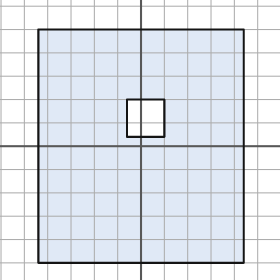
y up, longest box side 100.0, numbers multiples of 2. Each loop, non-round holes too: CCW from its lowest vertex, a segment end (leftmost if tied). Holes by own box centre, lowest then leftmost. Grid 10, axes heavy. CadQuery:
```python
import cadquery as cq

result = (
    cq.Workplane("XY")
    .moveTo(-44.0, -50.0)
    .lineTo(44.0, -50.0)
    .lineTo(44.0, 50.0)
    .lineTo(-44.0, 50.0)
    .close()
    .moveTo(-6.0, 4.0)
    .lineTo(10.0, 4.0)
    .lineTo(10.0, 20.0)
    .lineTo(-6.0, 20.0)
    .close()
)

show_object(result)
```